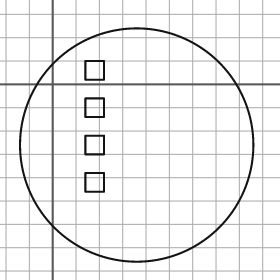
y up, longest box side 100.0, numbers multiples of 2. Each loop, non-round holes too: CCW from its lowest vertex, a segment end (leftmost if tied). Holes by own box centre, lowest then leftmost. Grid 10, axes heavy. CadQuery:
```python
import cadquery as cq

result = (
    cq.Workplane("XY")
    .moveTo(36.0, -26.0)
    .circle(50.0)
    .moveTo(14.0, -46.0)
    .lineTo(22.0, -46.0)
    .lineTo(22.0, -38.0)
    .lineTo(14.0, -38.0)
    .close()
    .moveTo(14.0, -30.0)
    .lineTo(22.0, -30.0)
    .lineTo(22.0, -22.0)
    .lineTo(14.0, -22.0)
    .close()
    .moveTo(14.0, -14.0)
    .lineTo(22.0, -14.0)
    .lineTo(22.0, -6.0)
    .lineTo(14.0, -6.0)
    .close()
    .moveTo(14.0, 2.0)
    .lineTo(22.0, 2.0)
    .lineTo(22.0, 10.0)
    .lineTo(14.0, 10.0)
    .close()
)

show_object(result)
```